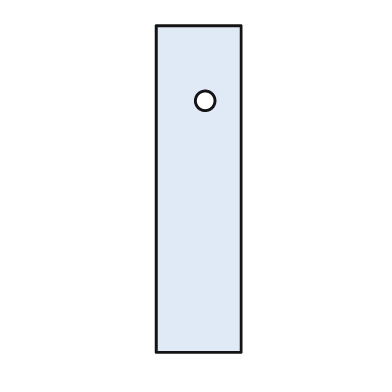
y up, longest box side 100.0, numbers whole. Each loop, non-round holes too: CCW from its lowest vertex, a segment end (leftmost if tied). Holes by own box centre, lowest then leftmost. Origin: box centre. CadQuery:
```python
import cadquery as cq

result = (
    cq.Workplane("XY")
    .moveTo(-13.0, -50.0)
    .lineTo(13.0, -50.0)
    .lineTo(13.0, 50.0)
    .lineTo(-13.0, 50.0)
    .close()
    .moveTo(2.0, 27.0)
    .circle(3.0)
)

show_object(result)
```